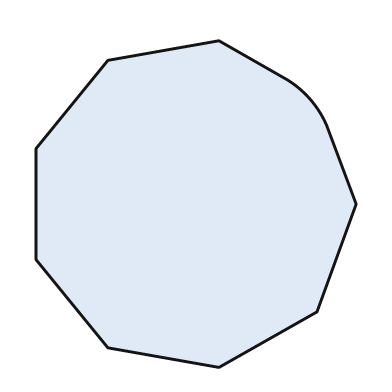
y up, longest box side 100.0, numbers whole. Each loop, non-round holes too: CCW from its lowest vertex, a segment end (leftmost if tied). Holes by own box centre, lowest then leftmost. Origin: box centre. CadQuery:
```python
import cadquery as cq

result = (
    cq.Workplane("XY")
    .moveTo(7.0, -50.0)
    .lineTo(37.0, -33.0)
    .lineTo(49.0, 0.0)
    .lineTo(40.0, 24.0)
    .threePointArc((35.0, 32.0), (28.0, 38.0))
    .lineTo(7.0, 50.0)
    .lineTo(-27.0, 44.0)
    .lineTo(-49.0, 17.0)
    .lineTo(-49.0, -17.0)
    .lineTo(-27.0, -44.0)
    .close()
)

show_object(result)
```